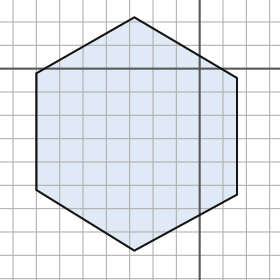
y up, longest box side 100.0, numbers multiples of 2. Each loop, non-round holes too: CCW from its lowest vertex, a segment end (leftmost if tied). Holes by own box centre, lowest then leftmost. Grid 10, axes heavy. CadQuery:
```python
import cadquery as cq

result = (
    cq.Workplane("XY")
    .moveTo(-28.0, -78.0)
    .lineTo(16.0, -54.0)
    .lineTo(16.0, -4.0)
    .lineTo(-28.0, 22.0)
    .lineTo(-70.0, -2.0)
    .lineTo(-70.0, -52.0)
    .close()
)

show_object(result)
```